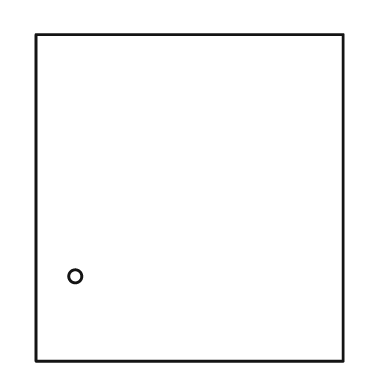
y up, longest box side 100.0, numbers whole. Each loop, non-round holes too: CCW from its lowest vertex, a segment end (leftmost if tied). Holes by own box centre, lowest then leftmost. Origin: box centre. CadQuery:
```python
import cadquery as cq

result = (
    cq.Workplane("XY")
    .moveTo(-47.0, -50.0)
    .lineTo(47.0, -50.0)
    .lineTo(47.0, 50.0)
    .lineTo(-47.0, 50.0)
    .close()
    .moveTo(-35.0, -24.0)
    .circle(2.0)
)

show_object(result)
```